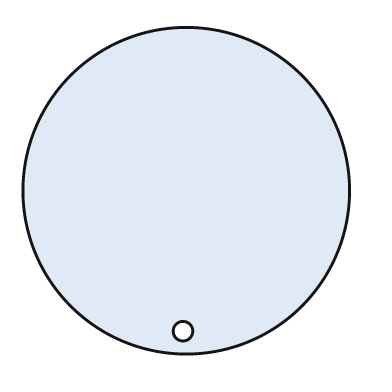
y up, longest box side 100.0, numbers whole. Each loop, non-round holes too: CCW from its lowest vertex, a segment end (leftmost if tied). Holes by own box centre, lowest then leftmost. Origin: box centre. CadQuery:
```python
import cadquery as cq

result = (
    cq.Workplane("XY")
    .moveTo(0.0, 0.0)
    .circle(50.0)
    .moveTo(-1.0, -43.0)
    .circle(3.0)
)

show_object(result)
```